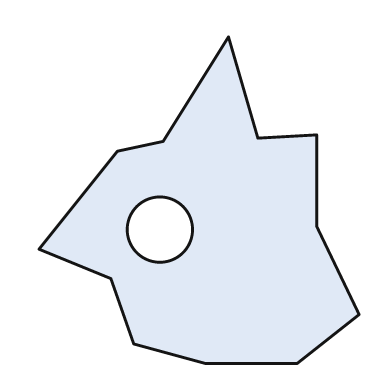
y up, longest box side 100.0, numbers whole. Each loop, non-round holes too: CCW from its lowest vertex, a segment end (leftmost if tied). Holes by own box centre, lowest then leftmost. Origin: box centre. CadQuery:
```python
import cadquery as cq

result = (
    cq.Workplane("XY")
    .moveTo(2.0, -50.0)
    .lineTo(30.0, -50.0)
    .lineTo(49.0, -35.0)
    .lineTo(36.0, -8.0)
    .lineTo(36.0, 20.0)
    .lineTo(18.0, 19.0)
    .lineTo(9.0, 50.0)
    .lineTo(-11.0, 18.0)
    .lineTo(-25.0, 15.0)
    .lineTo(-49.0, -15.0)
    .lineTo(-27.0, -24.0)
    .lineTo(-20.0, -44.0)
    .close()
    .moveTo(-12.0, -9.0)
    .circle(10.0)
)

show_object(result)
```